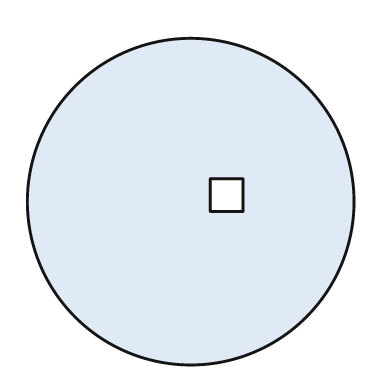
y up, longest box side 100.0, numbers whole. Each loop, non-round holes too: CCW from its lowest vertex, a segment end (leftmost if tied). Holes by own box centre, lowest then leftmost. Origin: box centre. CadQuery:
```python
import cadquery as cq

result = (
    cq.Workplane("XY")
    .moveTo(0.0, 0.0)
    .circle(50.0)
    .moveTo(6.0, -3.0)
    .lineTo(16.0, -3.0)
    .lineTo(16.0, 7.0)
    .lineTo(6.0, 7.0)
    .close()
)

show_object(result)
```